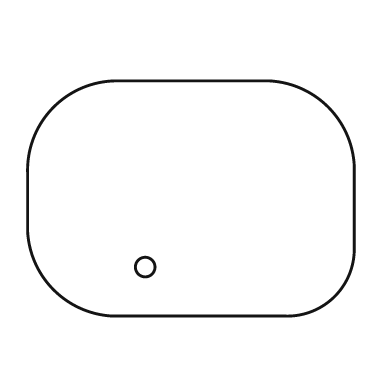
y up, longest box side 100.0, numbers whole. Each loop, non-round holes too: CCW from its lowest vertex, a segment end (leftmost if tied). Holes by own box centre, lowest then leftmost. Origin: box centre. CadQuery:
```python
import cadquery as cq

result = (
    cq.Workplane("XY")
    .moveTo(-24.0, -36.0)
    .lineTo(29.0, -36.0)
    .threePointArc((44.0, -30.0), (50.0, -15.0))
    .lineTo(50.0, 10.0)
    .threePointArc((42.0, 28.0), (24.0, 36.0))
    .lineTo(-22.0, 36.0)
    .threePointArc((-42.0, 28.0), (-50.0, 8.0))
    .lineTo(-50.0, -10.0)
    .threePointArc((-42.0, -28.0), (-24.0, -36.0))
    .close()
    .moveTo(-14.0, -21.0)
    .circle(3.0)
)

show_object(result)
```